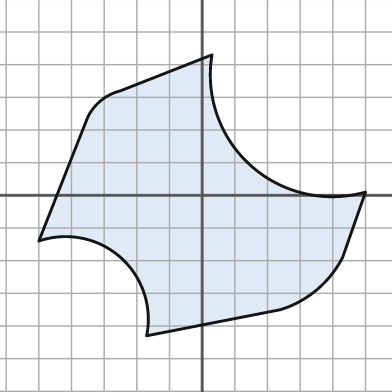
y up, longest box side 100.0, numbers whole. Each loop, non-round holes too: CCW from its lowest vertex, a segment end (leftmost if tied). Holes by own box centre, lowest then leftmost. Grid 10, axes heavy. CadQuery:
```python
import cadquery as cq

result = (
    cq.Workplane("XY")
    .moveTo(-17.0, -43.0)
    .lineTo(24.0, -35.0)
    .threePointArc((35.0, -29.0), (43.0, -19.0))
    .lineTo(50.0, 1.0)
    .threePointArc((15.0, 9.0), (3.0, 43.0))
    .lineTo(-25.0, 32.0)
    .threePointArc((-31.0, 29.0), (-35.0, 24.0))
    .lineTo(-50.0, -14.0)
    .threePointArc((-25.0, -19.0), (-17.0, -43.0))
    .close()
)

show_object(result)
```